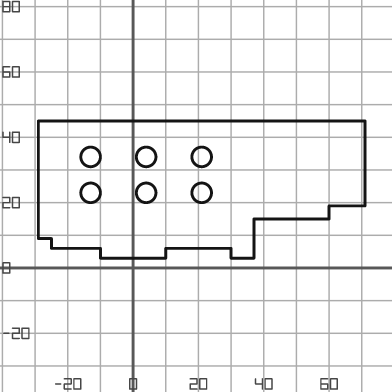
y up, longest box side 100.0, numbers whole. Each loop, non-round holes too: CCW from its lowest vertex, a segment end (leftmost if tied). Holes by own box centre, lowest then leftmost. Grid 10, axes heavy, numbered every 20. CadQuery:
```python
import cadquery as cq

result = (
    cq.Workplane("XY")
    .moveTo(-10.0, 3.0)
    .lineTo(10.0, 3.0)
    .lineTo(10.0, 6.0)
    .lineTo(30.0, 6.0)
    .lineTo(30.0, 3.0)
    .lineTo(37.0, 3.0)
    .lineTo(37.0, 15.0)
    .lineTo(60.0, 15.0)
    .lineTo(60.0, 19.0)
    .lineTo(71.0, 19.0)
    .lineTo(71.0, 45.0)
    .lineTo(-29.0, 45.0)
    .lineTo(-29.0, 9.0)
    .lineTo(-25.0, 9.0)
    .lineTo(-25.0, 6.0)
    .lineTo(-10.0, 6.0)
    .close()
    .moveTo(-13.0, 23.0)
    .circle(3.0)
    .moveTo(4.0, 23.0)
    .circle(3.0)
    .moveTo(21.0, 23.0)
    .circle(3.0)
    .moveTo(-13.0, 34.0)
    .circle(3.0)
    .moveTo(4.0, 34.0)
    .circle(3.0)
    .moveTo(21.0, 34.0)
    .circle(3.0)
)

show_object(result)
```